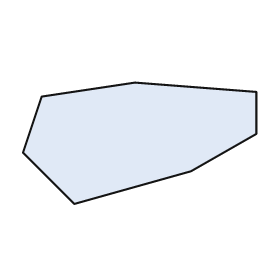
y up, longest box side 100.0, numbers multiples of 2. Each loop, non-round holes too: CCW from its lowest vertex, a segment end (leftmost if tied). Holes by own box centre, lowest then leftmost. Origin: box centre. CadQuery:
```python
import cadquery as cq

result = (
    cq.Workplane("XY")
    .moveTo(-28.0, -26.0)
    .lineTo(22.0, -12.0)
    .lineTo(50.0, 4.0)
    .lineTo(50.0, 22.0)
    .lineTo(-2.0, 26.0)
    .lineTo(-42.0, 20.0)
    .lineTo(-50.0, -4.0)
    .close()
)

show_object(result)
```